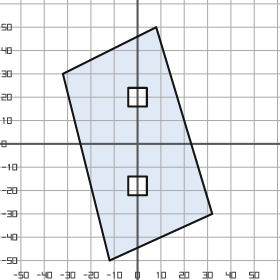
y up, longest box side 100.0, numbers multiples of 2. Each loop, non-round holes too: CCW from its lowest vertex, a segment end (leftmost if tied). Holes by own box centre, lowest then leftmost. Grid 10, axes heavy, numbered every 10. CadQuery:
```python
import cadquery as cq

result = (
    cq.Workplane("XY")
    .moveTo(-12.0, -50.0)
    .lineTo(32.0, -30.0)
    .lineTo(8.0, 50.0)
    .lineTo(-32.0, 30.0)
    .close()
    .moveTo(-4.0, -22.0)
    .lineTo(4.0, -22.0)
    .lineTo(4.0, -14.0)
    .lineTo(-4.0, -14.0)
    .close()
    .moveTo(-4.0, 16.0)
    .lineTo(4.0, 16.0)
    .lineTo(4.0, 24.0)
    .lineTo(-4.0, 24.0)
    .close()
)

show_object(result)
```